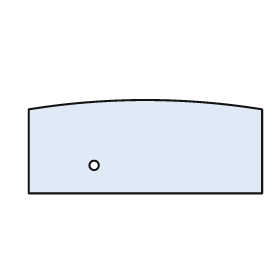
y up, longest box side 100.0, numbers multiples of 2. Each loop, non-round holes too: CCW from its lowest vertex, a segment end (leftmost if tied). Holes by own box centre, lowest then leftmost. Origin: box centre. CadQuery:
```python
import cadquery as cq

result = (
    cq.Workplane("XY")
    .moveTo(-50.0, -20.0)
    .lineTo(50.0, -20.0)
    .lineTo(50.0, 16.0)
    .threePointArc((0.0, 20.0), (-50.0, 16.0))
    .close()
    .moveTo(-22.0, -8.0)
    .circle(2.0)
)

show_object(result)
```